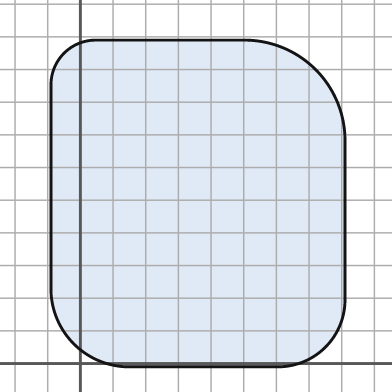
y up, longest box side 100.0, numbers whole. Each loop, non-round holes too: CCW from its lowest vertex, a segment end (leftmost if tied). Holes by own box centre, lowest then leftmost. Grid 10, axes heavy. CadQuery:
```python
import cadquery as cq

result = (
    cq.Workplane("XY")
    .moveTo(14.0, -1.0)
    .lineTo(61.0, -1.0)
    .threePointArc((75.0, 5.0), (81.0, 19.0))
    .lineTo(81.0, 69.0)
    .threePointArc((72.0, 90.0), (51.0, 99.0))
    .lineTo(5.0, 99.0)
    .threePointArc((-5.0, 95.0), (-9.0, 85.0))
    .lineTo(-9.0, 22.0)
    .threePointArc((-2.0, 6.0), (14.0, -1.0))
    .close()
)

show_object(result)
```